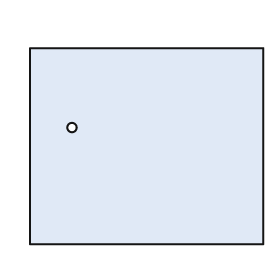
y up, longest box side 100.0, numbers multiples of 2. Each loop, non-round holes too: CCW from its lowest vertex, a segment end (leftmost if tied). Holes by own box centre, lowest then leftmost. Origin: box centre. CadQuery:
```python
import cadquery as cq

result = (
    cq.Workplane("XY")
    .moveTo(-50.0, -42.0)
    .lineTo(50.0, -42.0)
    .lineTo(50.0, 42.0)
    .lineTo(-50.0, 42.0)
    .close()
    .moveTo(-32.0, 8.0)
    .circle(2.0)
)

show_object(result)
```